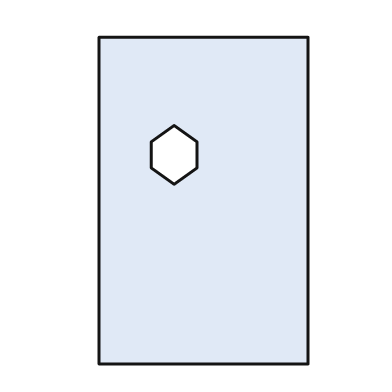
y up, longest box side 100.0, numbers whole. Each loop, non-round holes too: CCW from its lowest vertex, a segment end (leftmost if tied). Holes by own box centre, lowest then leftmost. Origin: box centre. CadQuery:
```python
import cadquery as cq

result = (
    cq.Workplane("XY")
    .moveTo(-32.0, -50.0)
    .lineTo(32.0, -50.0)
    .lineTo(32.0, 50.0)
    .lineTo(-32.0, 50.0)
    .close()
    .moveTo(-9.0, 5.0)
    .lineTo(-2.0, 10.0)
    .lineTo(-2.0, 18.0)
    .lineTo(-9.0, 23.0)
    .lineTo(-16.0, 18.0)
    .lineTo(-16.0, 10.0)
    .close()
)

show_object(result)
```